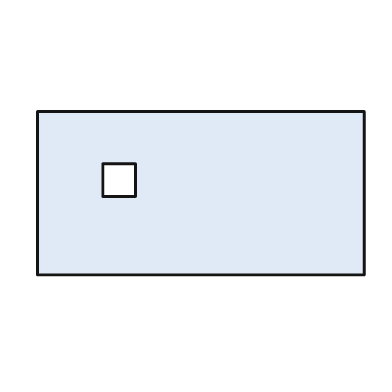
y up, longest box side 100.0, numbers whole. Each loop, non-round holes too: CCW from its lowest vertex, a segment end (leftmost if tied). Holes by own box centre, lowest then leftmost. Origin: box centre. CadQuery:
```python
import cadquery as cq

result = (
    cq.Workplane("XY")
    .moveTo(-50.0, -25.0)
    .lineTo(50.0, -25.0)
    .lineTo(50.0, 25.0)
    .lineTo(-50.0, 25.0)
    .close()
    .moveTo(-30.0, -1.0)
    .lineTo(-20.0, -1.0)
    .lineTo(-20.0, 9.0)
    .lineTo(-30.0, 9.0)
    .close()
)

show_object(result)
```